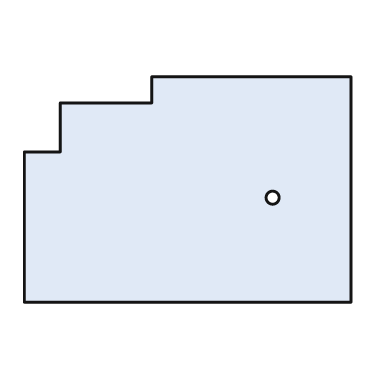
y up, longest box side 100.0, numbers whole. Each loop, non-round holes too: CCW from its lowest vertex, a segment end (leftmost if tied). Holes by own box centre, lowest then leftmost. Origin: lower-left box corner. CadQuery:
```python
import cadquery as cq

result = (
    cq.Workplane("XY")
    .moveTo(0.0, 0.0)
    .lineTo(100.0, 0.0)
    .lineTo(100.0, 69.0)
    .lineTo(39.0, 69.0)
    .lineTo(39.0, 61.0)
    .lineTo(11.0, 61.0)
    .lineTo(11.0, 46.0)
    .lineTo(0.0, 46.0)
    .close()
    .moveTo(76.0, 32.0)
    .circle(2.0)
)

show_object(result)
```